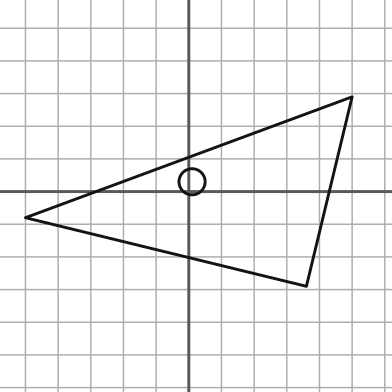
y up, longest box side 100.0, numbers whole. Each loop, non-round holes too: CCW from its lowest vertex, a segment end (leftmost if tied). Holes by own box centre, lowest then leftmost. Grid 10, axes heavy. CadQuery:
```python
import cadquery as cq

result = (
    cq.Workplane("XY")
    .moveTo(36.0, -29.0)
    .lineTo(50.0, 29.0)
    .lineTo(-50.0, -8.0)
    .close()
    .moveTo(1.0, 3.0)
    .circle(4.0)
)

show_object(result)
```